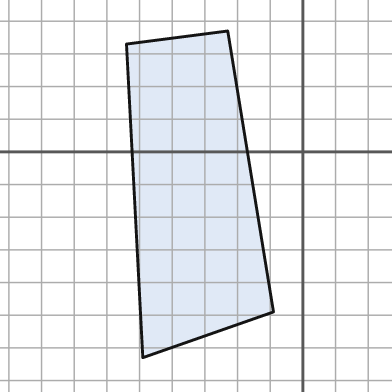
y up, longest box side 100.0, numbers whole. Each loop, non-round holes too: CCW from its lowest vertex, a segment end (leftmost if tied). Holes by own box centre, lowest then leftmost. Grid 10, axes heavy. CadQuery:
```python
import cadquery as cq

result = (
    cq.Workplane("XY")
    .moveTo(-49.0, -63.0)
    .lineTo(-9.0, -49.0)
    .lineTo(-23.0, 37.0)
    .lineTo(-54.0, 33.0)
    .close()
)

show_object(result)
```